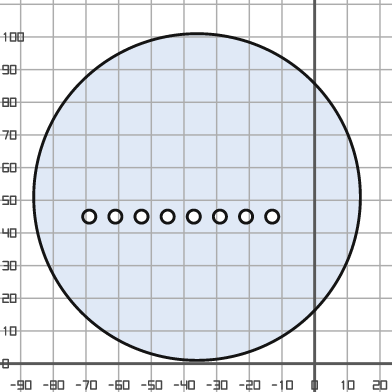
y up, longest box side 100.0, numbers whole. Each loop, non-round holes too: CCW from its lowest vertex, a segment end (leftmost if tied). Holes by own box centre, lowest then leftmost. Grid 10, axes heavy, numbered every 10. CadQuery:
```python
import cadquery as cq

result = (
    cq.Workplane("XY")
    .moveTo(-36.0, 51.0)
    .circle(50.0)
    .moveTo(-69.0, 45.0)
    .circle(2.0)
    .moveTo(-61.0, 45.0)
    .circle(2.0)
    .moveTo(-53.0, 45.0)
    .circle(2.0)
    .moveTo(-45.0, 45.0)
    .circle(2.0)
    .moveTo(-37.0, 45.0)
    .circle(2.0)
    .moveTo(-29.0, 45.0)
    .circle(2.0)
    .moveTo(-21.0, 45.0)
    .circle(2.0)
    .moveTo(-13.0, 45.0)
    .circle(2.0)
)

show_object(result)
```